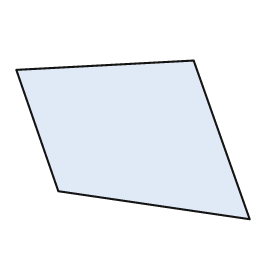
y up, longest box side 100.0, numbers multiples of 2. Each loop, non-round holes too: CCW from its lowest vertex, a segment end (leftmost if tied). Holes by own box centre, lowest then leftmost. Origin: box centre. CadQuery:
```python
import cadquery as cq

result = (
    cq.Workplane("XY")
    .moveTo(50.0, -34.0)
    .lineTo(26.0, 34.0)
    .lineTo(-50.0, 30.0)
    .lineTo(-32.0, -22.0)
    .close()
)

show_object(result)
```